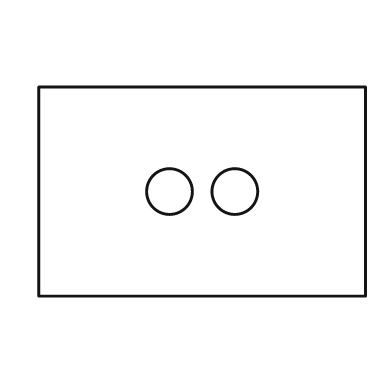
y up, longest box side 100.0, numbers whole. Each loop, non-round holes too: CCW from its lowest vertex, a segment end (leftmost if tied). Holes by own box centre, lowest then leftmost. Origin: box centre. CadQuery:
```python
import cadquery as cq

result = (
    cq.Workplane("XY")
    .moveTo(-50.0, -32.0)
    .lineTo(50.0, -32.0)
    .lineTo(50.0, 32.0)
    .lineTo(-50.0, 32.0)
    .close()
    .moveTo(-10.0, 0.0)
    .circle(7.0)
    .moveTo(10.0, 0.0)
    .circle(7.0)
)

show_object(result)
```